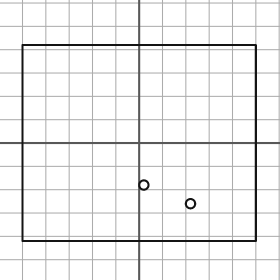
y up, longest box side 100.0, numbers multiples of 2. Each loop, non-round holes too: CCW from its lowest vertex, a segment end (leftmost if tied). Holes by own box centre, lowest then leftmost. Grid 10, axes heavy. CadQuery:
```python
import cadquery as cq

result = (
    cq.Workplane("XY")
    .moveTo(-50.0, -42.0)
    .lineTo(50.0, -42.0)
    .lineTo(50.0, 42.0)
    .lineTo(-50.0, 42.0)
    .close()
    .moveTo(22.0, -26.0)
    .circle(2.0)
    .moveTo(2.0, -18.0)
    .circle(2.0)
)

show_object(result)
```